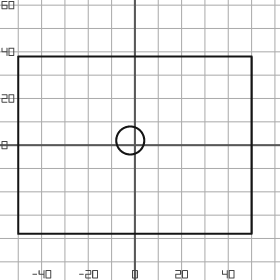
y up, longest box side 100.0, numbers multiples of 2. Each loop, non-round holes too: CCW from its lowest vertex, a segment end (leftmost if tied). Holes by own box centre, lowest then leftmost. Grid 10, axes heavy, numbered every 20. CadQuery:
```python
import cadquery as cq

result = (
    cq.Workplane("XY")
    .moveTo(-50.0, -38.0)
    .lineTo(50.0, -38.0)
    .lineTo(50.0, 38.0)
    .lineTo(-50.0, 38.0)
    .close()
    .moveTo(-2.0, 2.0)
    .circle(6.0)
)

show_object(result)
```